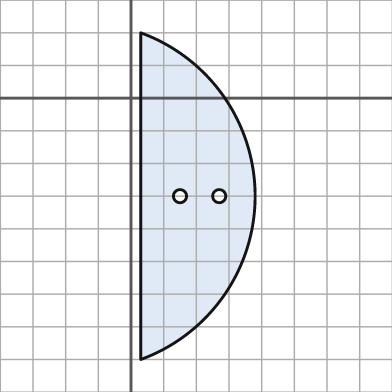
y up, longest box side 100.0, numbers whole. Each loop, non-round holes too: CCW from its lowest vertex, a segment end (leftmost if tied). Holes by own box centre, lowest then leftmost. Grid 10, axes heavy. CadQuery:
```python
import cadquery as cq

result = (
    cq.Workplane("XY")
    .moveTo(3.0, -80.0)
    .threePointArc((38.0, -30.0), (3.0, 20.0))
    .close()
    .moveTo(15.0, -30.0)
    .circle(2.0)
    .moveTo(27.0, -30.0)
    .circle(2.0)
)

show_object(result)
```